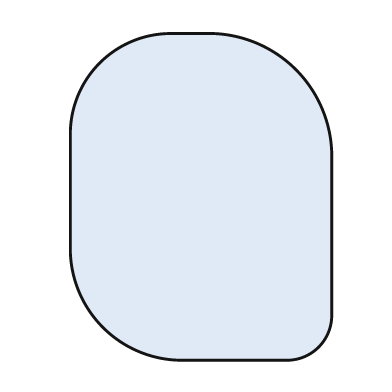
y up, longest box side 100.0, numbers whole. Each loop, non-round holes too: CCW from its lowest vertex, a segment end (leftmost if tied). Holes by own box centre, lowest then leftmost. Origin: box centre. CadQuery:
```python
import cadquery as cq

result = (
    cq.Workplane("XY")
    .moveTo(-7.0, -50.0)
    .lineTo(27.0, -50.0)
    .threePointArc((36.0, -46.0), (40.0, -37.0))
    .lineTo(40.0, 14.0)
    .threePointArc((29.0, 39.0), (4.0, 50.0))
    .lineTo(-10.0, 50.0)
    .threePointArc((-31.0, 41.0), (-40.0, 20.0))
    .lineTo(-40.0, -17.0)
    .threePointArc((-30.0, -40.0), (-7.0, -50.0))
    .close()
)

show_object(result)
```